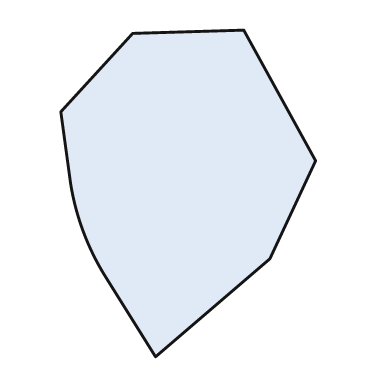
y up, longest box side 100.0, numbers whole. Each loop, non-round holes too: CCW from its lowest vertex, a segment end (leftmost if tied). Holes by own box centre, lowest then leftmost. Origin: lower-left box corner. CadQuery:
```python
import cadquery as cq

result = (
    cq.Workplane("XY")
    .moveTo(29.0, 0.0)
    .lineTo(64.0, 30.0)
    .lineTo(78.0, 60.0)
    .lineTo(56.0, 100.0)
    .lineTo(22.0, 99.0)
    .lineTo(0.0, 75.0)
    .lineTo(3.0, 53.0)
    .threePointArc((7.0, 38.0), (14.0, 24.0))
    .close()
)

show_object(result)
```